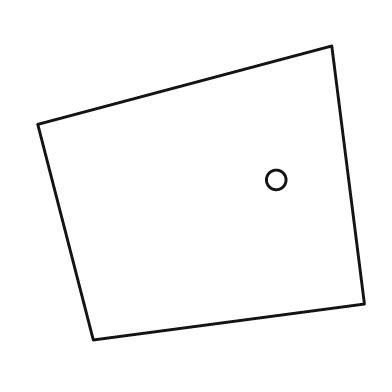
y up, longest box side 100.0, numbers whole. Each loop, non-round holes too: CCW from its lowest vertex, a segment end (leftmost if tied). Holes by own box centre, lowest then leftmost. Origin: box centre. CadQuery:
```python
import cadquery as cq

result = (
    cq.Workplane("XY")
    .moveTo(-33.0, -45.0)
    .lineTo(50.0, -34.0)
    .lineTo(40.0, 45.0)
    .lineTo(-50.0, 21.0)
    .close()
    .moveTo(23.0, 4.0)
    .circle(3.0)
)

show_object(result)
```